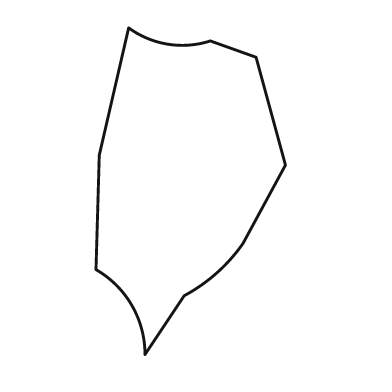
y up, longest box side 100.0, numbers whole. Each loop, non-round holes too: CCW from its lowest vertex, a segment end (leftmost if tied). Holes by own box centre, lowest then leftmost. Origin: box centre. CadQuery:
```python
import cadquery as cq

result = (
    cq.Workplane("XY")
    .moveTo(-14.0, -50.0)
    .lineTo(-2.0, -32.0)
    .threePointArc((8.0, -25.0), (16.0, -16.0))
    .lineTo(29.0, 8.0)
    .lineTo(20.0, 41.0)
    .lineTo(6.0, 46.0)
    .threePointArc((-7.0, 45.0), (-19.0, 50.0))
    .lineTo(-28.0, 11.0)
    .lineTo(-29.0, -24.0)
    .threePointArc((-18.0, -35.0), (-14.0, -50.0))
    .close()
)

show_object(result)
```